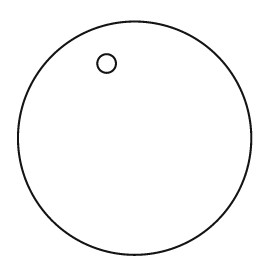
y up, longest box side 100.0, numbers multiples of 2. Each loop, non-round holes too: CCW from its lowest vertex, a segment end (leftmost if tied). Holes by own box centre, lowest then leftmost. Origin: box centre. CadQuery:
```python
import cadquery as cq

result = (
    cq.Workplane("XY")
    .moveTo(0.0, 0.0)
    .circle(50.0)
    .moveTo(-12.0, 32.0)
    .circle(4.0)
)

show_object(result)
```